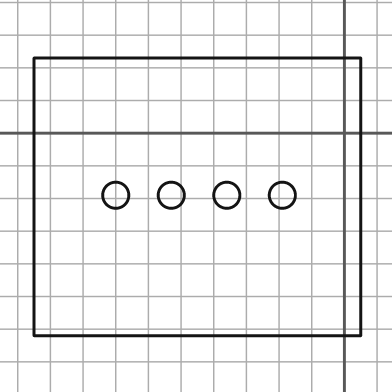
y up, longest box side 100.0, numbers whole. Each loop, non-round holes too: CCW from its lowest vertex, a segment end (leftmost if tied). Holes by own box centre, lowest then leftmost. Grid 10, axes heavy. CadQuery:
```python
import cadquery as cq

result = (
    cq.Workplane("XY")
    .moveTo(-95.0, -62.0)
    .lineTo(5.0, -62.0)
    .lineTo(5.0, 23.0)
    .lineTo(-95.0, 23.0)
    .close()
    .moveTo(-70.0, -19.0)
    .circle(4.0)
    .moveTo(-53.0, -19.0)
    .circle(4.0)
    .moveTo(-36.0, -19.0)
    .circle(4.0)
    .moveTo(-19.0, -19.0)
    .circle(4.0)
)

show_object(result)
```